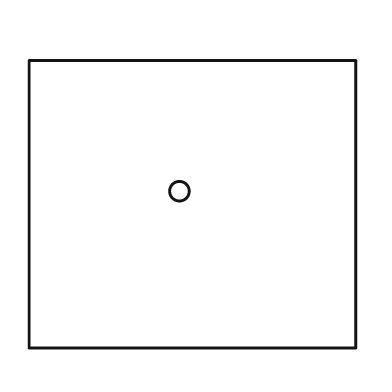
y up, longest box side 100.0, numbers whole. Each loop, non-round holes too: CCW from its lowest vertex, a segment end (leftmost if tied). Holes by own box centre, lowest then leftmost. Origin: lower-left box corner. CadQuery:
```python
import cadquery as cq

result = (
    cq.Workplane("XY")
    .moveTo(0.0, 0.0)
    .lineTo(100.0, 0.0)
    .lineTo(100.0, 88.0)
    .lineTo(0.0, 88.0)
    .close()
    .moveTo(46.0, 48.0)
    .circle(3.0)
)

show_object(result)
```